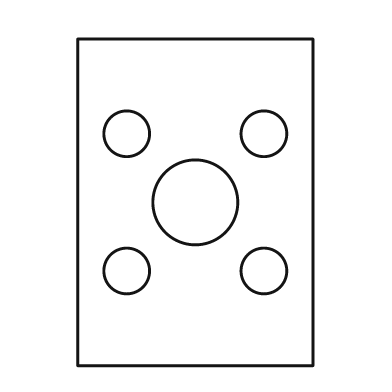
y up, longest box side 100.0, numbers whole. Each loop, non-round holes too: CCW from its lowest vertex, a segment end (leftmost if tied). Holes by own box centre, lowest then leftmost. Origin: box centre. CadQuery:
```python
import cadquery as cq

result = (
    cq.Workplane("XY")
    .moveTo(-36.0, -50.0)
    .lineTo(36.0, -50.0)
    .lineTo(36.0, 50.0)
    .lineTo(-36.0, 50.0)
    .close()
    .moveTo(-21.0, -21.0)
    .circle(7.0)
    .moveTo(21.0, -21.0)
    .circle(7.0)
    .moveTo(0.0, 0.0)
    .circle(13.0)
    .moveTo(-21.0, 21.0)
    .circle(7.0)
    .moveTo(21.0, 21.0)
    .circle(7.0)
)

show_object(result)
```